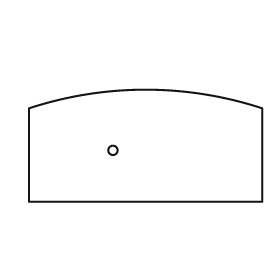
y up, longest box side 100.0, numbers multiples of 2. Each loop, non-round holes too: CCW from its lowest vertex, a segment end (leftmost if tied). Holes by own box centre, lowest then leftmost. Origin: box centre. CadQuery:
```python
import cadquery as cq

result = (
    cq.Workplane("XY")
    .moveTo(-50.0, -24.0)
    .lineTo(50.0, -24.0)
    .lineTo(50.0, 16.0)
    .threePointArc((0.0, 24.0), (-50.0, 16.0))
    .close()
    .moveTo(-14.0, -2.0)
    .circle(2.0)
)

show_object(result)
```